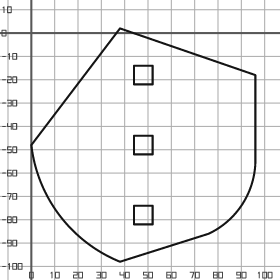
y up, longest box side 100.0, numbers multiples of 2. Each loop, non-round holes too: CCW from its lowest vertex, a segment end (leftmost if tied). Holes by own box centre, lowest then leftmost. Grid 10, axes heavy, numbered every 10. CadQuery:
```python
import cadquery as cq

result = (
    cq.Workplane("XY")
    .moveTo(38.0, -98.0)
    .lineTo(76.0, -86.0)
    .threePointArc((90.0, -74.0), (96.0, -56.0))
    .lineTo(96.0, -18.0)
    .lineTo(38.0, 2.0)
    .lineTo(0.0, -48.0)
    .threePointArc((12.0, -78.0), (38.0, -98.0))
    .close()
    .moveTo(44.0, -82.0)
    .lineTo(52.0, -82.0)
    .lineTo(52.0, -74.0)
    .lineTo(44.0, -74.0)
    .close()
    .moveTo(44.0, -52.0)
    .lineTo(52.0, -52.0)
    .lineTo(52.0, -44.0)
    .lineTo(44.0, -44.0)
    .close()
    .moveTo(44.0, -22.0)
    .lineTo(52.0, -22.0)
    .lineTo(52.0, -14.0)
    .lineTo(44.0, -14.0)
    .close()
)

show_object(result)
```